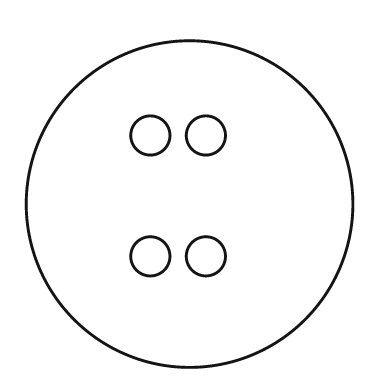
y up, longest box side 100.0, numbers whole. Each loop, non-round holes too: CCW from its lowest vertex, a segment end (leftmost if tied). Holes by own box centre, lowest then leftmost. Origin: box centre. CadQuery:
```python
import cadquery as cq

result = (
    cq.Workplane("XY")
    .moveTo(0.0, 0.0)
    .circle(50.0)
    .moveTo(-12.0, -16.0)
    .circle(6.0)
    .moveTo(5.0, -16.0)
    .circle(6.0)
    .moveTo(-12.0, 21.0)
    .circle(6.0)
    .moveTo(5.0, 21.0)
    .circle(6.0)
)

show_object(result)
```